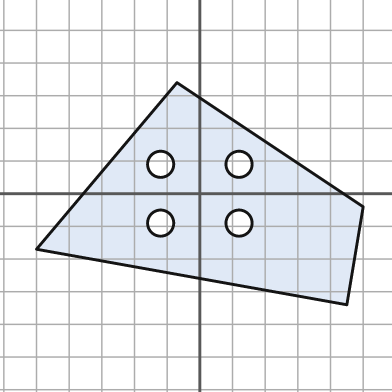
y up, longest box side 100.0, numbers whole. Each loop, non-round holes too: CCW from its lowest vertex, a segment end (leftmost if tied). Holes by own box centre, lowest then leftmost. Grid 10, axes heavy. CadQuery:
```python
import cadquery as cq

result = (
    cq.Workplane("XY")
    .moveTo(45.0, -34.0)
    .lineTo(50.0, -4.0)
    .lineTo(-7.0, 34.0)
    .lineTo(-50.0, -17.0)
    .close()
    .moveTo(-12.0, -9.0)
    .circle(4.0)
    .moveTo(12.0, -9.0)
    .circle(4.0)
    .moveTo(-12.0, 9.0)
    .circle(4.0)
    .moveTo(12.0, 9.0)
    .circle(4.0)
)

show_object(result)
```